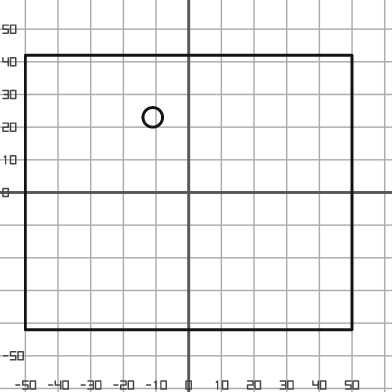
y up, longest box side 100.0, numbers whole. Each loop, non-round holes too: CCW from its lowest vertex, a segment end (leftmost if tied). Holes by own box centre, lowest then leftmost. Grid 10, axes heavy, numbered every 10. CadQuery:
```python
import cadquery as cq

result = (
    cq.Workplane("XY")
    .moveTo(-50.0, -42.0)
    .lineTo(50.0, -42.0)
    .lineTo(50.0, 42.0)
    .lineTo(-50.0, 42.0)
    .close()
    .moveTo(-11.0, 23.0)
    .circle(3.0)
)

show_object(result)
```